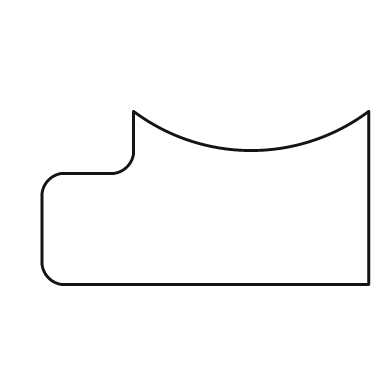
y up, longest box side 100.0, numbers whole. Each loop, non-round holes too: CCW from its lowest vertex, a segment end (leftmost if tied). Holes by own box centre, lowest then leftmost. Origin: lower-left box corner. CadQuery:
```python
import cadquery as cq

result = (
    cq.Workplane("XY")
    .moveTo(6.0, 0.0)
    .lineTo(100.0, 0.0)
    .lineTo(100.0, 53.0)
    .threePointArc((64.0, 41.0), (28.0, 53.0))
    .lineTo(28.0, 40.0)
    .threePointArc((26.0, 36.0), (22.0, 34.0))
    .lineTo(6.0, 34.0)
    .threePointArc((2.0, 32.0), (0.0, 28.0))
    .lineTo(0.0, 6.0)
    .threePointArc((2.0, 2.0), (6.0, 0.0))
    .close()
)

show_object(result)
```